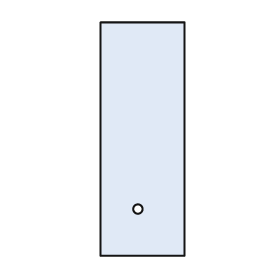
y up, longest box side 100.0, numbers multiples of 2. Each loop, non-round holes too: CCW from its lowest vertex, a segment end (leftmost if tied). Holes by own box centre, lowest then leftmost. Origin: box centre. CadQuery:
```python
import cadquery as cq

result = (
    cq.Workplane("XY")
    .moveTo(-18.0, -50.0)
    .lineTo(18.0, -50.0)
    .lineTo(18.0, 50.0)
    .lineTo(-18.0, 50.0)
    .close()
    .moveTo(-2.0, -30.0)
    .circle(2.0)
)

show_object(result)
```